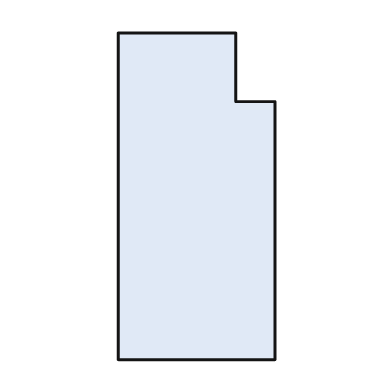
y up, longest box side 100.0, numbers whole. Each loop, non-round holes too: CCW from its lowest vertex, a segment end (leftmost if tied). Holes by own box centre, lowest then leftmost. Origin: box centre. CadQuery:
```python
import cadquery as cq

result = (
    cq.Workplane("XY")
    .moveTo(-24.0, -50.0)
    .lineTo(24.0, -50.0)
    .lineTo(24.0, 29.0)
    .lineTo(12.0, 29.0)
    .lineTo(12.0, 50.0)
    .lineTo(-24.0, 50.0)
    .close()
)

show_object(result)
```